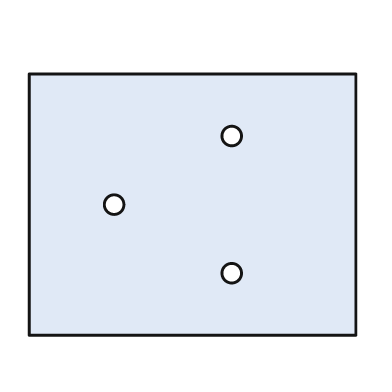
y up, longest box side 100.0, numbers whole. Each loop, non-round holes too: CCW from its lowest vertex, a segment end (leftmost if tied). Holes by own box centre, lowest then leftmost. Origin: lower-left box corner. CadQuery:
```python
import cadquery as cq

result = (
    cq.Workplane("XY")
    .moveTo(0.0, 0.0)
    .lineTo(100.0, 0.0)
    .lineTo(100.0, 80.0)
    .lineTo(0.0, 80.0)
    .close()
    .moveTo(62.0, 19.0)
    .circle(3.0)
    .moveTo(26.0, 40.0)
    .circle(3.0)
    .moveTo(62.0, 61.0)
    .circle(3.0)
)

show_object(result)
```